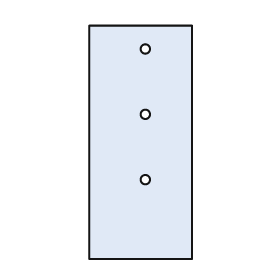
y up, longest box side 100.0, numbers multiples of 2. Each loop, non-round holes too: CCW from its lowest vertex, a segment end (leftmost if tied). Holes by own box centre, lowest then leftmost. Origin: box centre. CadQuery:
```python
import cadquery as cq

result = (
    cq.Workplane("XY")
    .moveTo(-22.0, -50.0)
    .lineTo(22.0, -50.0)
    .lineTo(22.0, 50.0)
    .lineTo(-22.0, 50.0)
    .close()
    .moveTo(2.0, -16.0)
    .circle(2.0)
    .moveTo(2.0, 12.0)
    .circle(2.0)
    .moveTo(2.0, 40.0)
    .circle(2.0)
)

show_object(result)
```